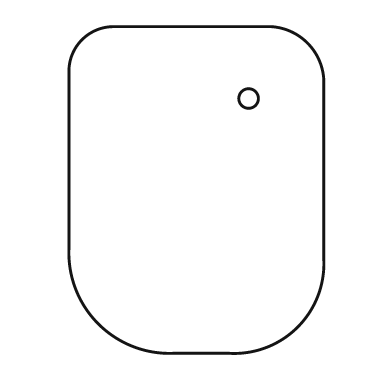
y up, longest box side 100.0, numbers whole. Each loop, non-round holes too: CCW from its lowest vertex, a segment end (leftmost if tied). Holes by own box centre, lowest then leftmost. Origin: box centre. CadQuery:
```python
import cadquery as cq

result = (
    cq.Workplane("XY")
    .moveTo(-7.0, -50.0)
    .lineTo(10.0, -50.0)
    .threePointArc((31.0, -42.0), (39.0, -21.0))
    .lineTo(39.0, 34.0)
    .threePointArc((34.0, 45.0), (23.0, 50.0))
    .lineTo(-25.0, 50.0)
    .threePointArc((-35.0, 46.0), (-39.0, 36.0))
    .lineTo(-39.0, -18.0)
    .threePointArc((-30.0, -41.0), (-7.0, -50.0))
    .close()
    .moveTo(16.0, 28.0)
    .circle(3.0)
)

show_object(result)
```